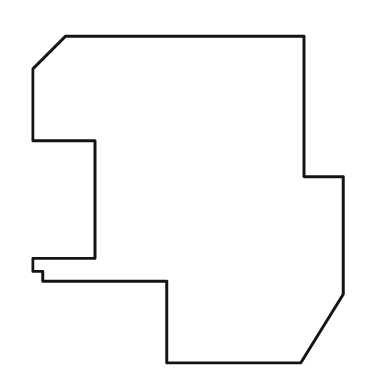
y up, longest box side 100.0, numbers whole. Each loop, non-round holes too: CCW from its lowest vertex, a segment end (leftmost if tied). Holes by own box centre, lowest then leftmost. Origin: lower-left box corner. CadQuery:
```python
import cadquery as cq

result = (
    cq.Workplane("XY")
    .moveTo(41.0, 0.0)
    .lineTo(82.0, 0.0)
    .lineTo(95.0, 21.0)
    .lineTo(95.0, 57.0)
    .lineTo(83.0, 57.0)
    .lineTo(83.0, 100.0)
    .lineTo(10.0, 100.0)
    .lineTo(0.0, 90.0)
    .lineTo(0.0, 68.0)
    .lineTo(19.0, 68.0)
    .lineTo(19.0, 32.0)
    .lineTo(0.0, 32.0)
    .lineTo(0.0, 28.0)
    .lineTo(3.0, 28.0)
    .lineTo(3.0, 25.0)
    .lineTo(41.0, 25.0)
    .close()
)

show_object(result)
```